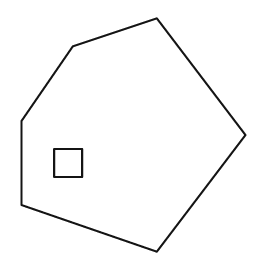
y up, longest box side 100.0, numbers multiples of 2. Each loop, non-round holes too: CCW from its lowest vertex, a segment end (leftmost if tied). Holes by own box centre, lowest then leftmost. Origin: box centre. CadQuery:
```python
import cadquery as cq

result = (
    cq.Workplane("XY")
    .moveTo(10.0, -50.0)
    .lineTo(48.0, 0.0)
    .lineTo(10.0, 50.0)
    .lineTo(-26.0, 38.0)
    .lineTo(-48.0, 6.0)
    .lineTo(-48.0, -30.0)
    .close()
    .moveTo(-34.0, -18.0)
    .lineTo(-22.0, -18.0)
    .lineTo(-22.0, -6.0)
    .lineTo(-34.0, -6.0)
    .close()
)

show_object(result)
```